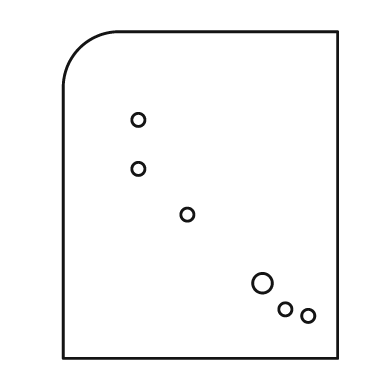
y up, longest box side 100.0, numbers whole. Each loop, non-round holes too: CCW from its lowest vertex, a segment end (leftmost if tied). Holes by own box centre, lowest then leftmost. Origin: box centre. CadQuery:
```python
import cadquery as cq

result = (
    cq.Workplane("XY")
    .moveTo(-42.0, -50.0)
    .lineTo(42.0, -50.0)
    .lineTo(42.0, 50.0)
    .lineTo(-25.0, 50.0)
    .threePointArc((-37.0, 45.0), (-42.0, 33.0))
    .close()
    .moveTo(33.0, -37.0)
    .circle(2.0)
    .moveTo(26.0, -35.0)
    .circle(2.0)
    .moveTo(19.0, -27.0)
    .circle(3.0)
    .moveTo(-4.0, -6.0)
    .circle(2.0)
    .moveTo(-19.0, 8.0)
    .circle(2.0)
    .moveTo(-19.0, 23.0)
    .circle(2.0)
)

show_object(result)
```